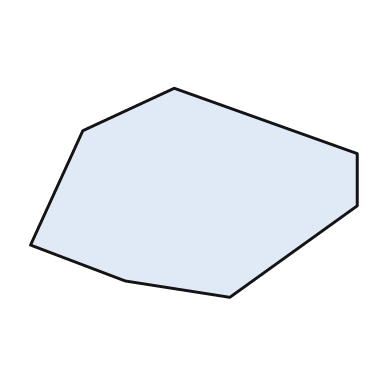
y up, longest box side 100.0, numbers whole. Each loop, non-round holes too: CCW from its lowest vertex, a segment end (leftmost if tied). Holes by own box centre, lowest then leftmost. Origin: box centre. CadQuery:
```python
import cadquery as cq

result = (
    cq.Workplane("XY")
    .moveTo(11.0, -32.0)
    .lineTo(50.0, -4.0)
    .lineTo(50.0, 12.0)
    .lineTo(-6.0, 32.0)
    .lineTo(-34.0, 19.0)
    .lineTo(-50.0, -16.0)
    .lineTo(-21.0, -27.0)
    .close()
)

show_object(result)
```